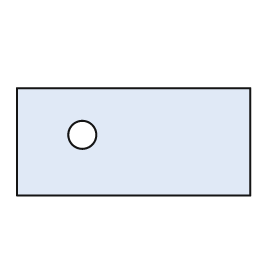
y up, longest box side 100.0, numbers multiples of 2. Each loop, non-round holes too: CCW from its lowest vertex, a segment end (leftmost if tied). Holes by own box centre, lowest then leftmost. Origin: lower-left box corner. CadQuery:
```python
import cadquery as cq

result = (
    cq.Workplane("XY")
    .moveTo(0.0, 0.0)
    .lineTo(100.0, 0.0)
    .lineTo(100.0, 46.0)
    .lineTo(0.0, 46.0)
    .close()
    .moveTo(28.0, 26.0)
    .circle(6.0)
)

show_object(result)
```